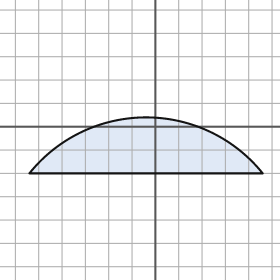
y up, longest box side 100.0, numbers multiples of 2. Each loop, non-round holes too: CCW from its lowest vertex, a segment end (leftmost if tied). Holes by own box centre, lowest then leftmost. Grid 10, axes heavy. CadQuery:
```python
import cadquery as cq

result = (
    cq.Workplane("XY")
    .moveTo(-54.0, -20.0)
    .lineTo(46.0, -20.0)
    .threePointArc((-4.0, 4.0), (-54.0, -20.0))
    .close()
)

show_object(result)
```